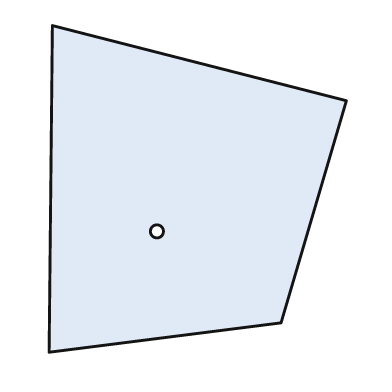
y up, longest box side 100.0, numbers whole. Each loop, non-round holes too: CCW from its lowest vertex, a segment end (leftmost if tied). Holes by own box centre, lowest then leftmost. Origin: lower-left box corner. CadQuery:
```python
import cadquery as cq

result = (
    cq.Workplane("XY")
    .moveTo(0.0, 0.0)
    .lineTo(71.0, 9.0)
    .lineTo(91.0, 77.0)
    .lineTo(1.0, 100.0)
    .close()
    .moveTo(33.0, 37.0)
    .circle(2.0)
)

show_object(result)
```